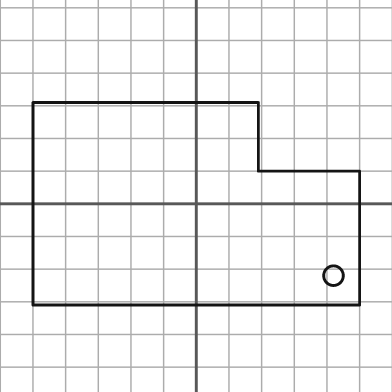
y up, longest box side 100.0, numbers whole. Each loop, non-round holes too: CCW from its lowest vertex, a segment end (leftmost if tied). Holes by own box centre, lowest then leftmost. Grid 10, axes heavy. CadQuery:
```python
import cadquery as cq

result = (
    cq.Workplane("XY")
    .moveTo(-50.0, -31.0)
    .lineTo(50.0, -31.0)
    .lineTo(50.0, 10.0)
    .lineTo(19.0, 10.0)
    .lineTo(19.0, 31.0)
    .lineTo(-50.0, 31.0)
    .close()
    .moveTo(42.0, -22.0)
    .circle(3.0)
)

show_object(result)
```